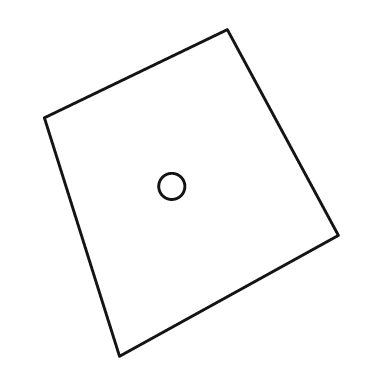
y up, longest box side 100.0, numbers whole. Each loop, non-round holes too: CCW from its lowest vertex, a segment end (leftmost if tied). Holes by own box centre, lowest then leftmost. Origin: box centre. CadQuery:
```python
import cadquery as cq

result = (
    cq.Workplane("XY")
    .moveTo(-22.0, -50.0)
    .lineTo(45.0, -13.0)
    .lineTo(11.0, 50.0)
    .lineTo(-45.0, 23.0)
    .close()
    .moveTo(-6.0, 2.0)
    .circle(4.0)
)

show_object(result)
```